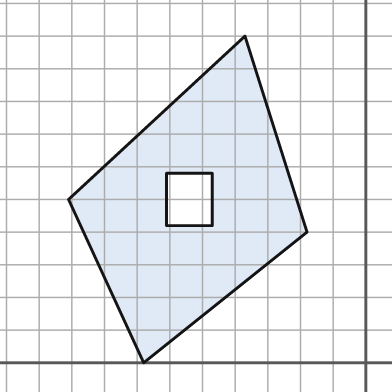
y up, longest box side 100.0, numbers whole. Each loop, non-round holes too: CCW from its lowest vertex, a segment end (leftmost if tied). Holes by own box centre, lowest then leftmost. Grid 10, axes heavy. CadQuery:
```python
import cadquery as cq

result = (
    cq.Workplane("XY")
    .moveTo(-68.0, 0.0)
    .lineTo(-18.0, 40.0)
    .lineTo(-37.0, 100.0)
    .lineTo(-91.0, 50.0)
    .close()
    .moveTo(-61.0, 42.0)
    .lineTo(-47.0, 42.0)
    .lineTo(-47.0, 58.0)
    .lineTo(-61.0, 58.0)
    .close()
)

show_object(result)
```